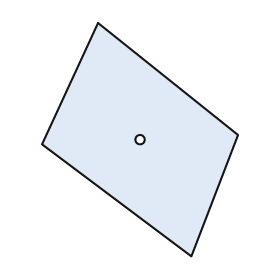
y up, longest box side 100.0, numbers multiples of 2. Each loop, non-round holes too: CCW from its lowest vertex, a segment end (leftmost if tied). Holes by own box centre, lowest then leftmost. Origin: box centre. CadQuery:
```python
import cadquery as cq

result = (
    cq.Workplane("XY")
    .moveTo(22.0, -50.0)
    .lineTo(42.0, 2.0)
    .lineTo(-18.0, 50.0)
    .lineTo(-42.0, -2.0)
    .close()
    .moveTo(0.0, 0.0)
    .circle(2.0)
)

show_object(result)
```